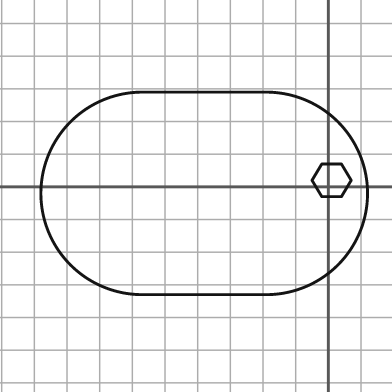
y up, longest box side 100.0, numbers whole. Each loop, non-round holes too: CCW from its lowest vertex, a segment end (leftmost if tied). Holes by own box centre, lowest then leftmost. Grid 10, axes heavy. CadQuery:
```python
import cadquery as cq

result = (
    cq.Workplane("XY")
    .moveTo(-57.0, -33.0)
    .lineTo(-19.0, -33.0)
    .threePointArc((12.0, -2.0), (-19.0, 29.0))
    .lineTo(-57.0, 29.0)
    .threePointArc((-88.0, -2.0), (-57.0, -33.0))
    .close()
    .moveTo(-2.0, -3.0)
    .lineTo(4.0, -3.0)
    .lineTo(7.0, 2.0)
    .lineTo(4.0, 7.0)
    .lineTo(-2.0, 7.0)
    .lineTo(-5.0, 2.0)
    .close()
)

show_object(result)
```